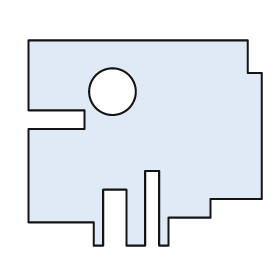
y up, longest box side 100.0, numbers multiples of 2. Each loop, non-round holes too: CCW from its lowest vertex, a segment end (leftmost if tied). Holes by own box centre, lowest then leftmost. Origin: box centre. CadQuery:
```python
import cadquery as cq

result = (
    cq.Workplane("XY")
    .moveTo(-22.0, -44.0)
    .lineTo(-18.0, -44.0)
    .lineTo(-18.0, -20.0)
    .lineTo(-8.0, -20.0)
    .lineTo(-8.0, -44.0)
    .lineTo(0.0, -44.0)
    .lineTo(0.0, -12.0)
    .lineTo(6.0, -12.0)
    .lineTo(6.0, -44.0)
    .lineTo(10.0, -44.0)
    .lineTo(10.0, -32.0)
    .lineTo(28.0, -32.0)
    .lineTo(28.0, -24.0)
    .lineTo(50.0, -24.0)
    .lineTo(50.0, 30.0)
    .lineTo(44.0, 30.0)
    .lineTo(44.0, 44.0)
    .lineTo(-50.0, 44.0)
    .lineTo(-50.0, 14.0)
    .lineTo(-26.0, 14.0)
    .lineTo(-26.0, 6.0)
    .lineTo(-50.0, 6.0)
    .lineTo(-50.0, -34.0)
    .lineTo(-22.0, -34.0)
    .close()
    .moveTo(-14.0, 22.0)
    .circle(10.0)
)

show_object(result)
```